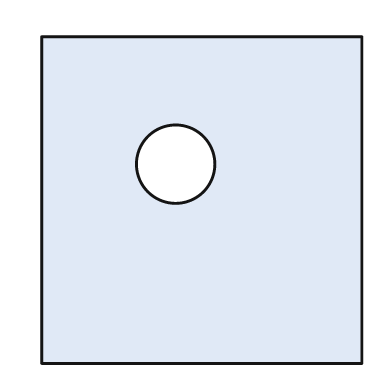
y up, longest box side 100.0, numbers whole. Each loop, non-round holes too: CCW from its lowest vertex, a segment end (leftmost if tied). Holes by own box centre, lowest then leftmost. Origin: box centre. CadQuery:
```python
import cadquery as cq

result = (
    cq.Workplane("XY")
    .moveTo(-49.0, -50.0)
    .lineTo(49.0, -50.0)
    .lineTo(49.0, 50.0)
    .lineTo(-49.0, 50.0)
    .close()
    .moveTo(-8.0, 11.0)
    .circle(12.0)
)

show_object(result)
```